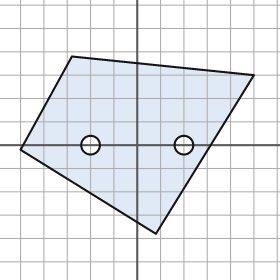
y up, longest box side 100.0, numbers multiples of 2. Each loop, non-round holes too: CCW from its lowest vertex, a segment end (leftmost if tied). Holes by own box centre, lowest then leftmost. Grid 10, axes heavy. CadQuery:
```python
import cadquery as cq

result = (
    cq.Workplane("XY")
    .moveTo(8.0, -38.0)
    .lineTo(50.0, 30.0)
    .lineTo(-28.0, 38.0)
    .lineTo(-50.0, -2.0)
    .close()
    .moveTo(-20.0, 0.0)
    .circle(4.0)
    .moveTo(20.0, 0.0)
    .circle(4.0)
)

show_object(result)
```